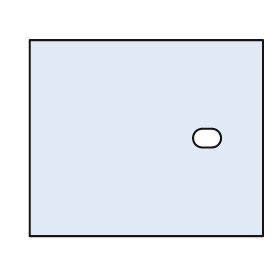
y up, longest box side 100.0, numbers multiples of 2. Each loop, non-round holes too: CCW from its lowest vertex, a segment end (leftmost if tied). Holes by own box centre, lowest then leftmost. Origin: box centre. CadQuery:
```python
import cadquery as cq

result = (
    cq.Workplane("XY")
    .moveTo(-50.0, -42.0)
    .lineTo(50.0, -42.0)
    .lineTo(50.0, 42.0)
    .lineTo(-50.0, 42.0)
    .close()
    .moveTo(24.0, -4.0)
    .lineTo(28.0, -4.0)
    .threePointArc((32.0, 0.0), (28.0, 4.0))
    .lineTo(24.0, 4.0)
    .threePointArc((20.0, 0.0), (24.0, -4.0))
    .close()
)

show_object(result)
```